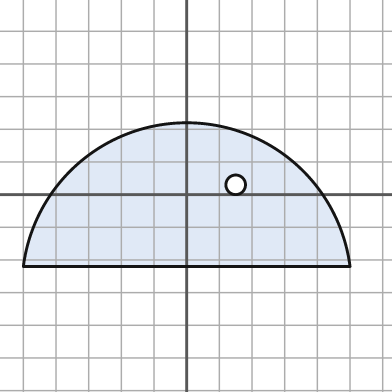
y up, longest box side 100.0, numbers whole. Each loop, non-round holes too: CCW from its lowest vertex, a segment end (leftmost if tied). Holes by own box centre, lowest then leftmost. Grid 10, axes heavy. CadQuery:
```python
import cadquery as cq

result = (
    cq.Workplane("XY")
    .moveTo(-50.0, -22.0)
    .lineTo(50.0, -22.0)
    .threePointArc((0.0, 22.0), (-50.0, -22.0))
    .close()
    .moveTo(15.0, 3.0)
    .circle(3.0)
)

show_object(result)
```